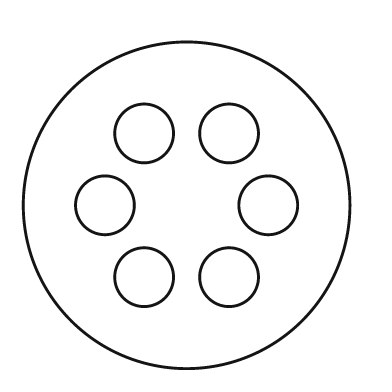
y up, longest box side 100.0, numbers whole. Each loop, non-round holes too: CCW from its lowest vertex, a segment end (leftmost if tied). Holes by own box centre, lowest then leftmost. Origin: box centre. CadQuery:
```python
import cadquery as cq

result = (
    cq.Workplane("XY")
    .moveTo(0.0, 0.0)
    .circle(50.0)
    .moveTo(-13.0, -22.0)
    .circle(9.0)
    .moveTo(13.0, -22.0)
    .circle(9.0)
    .moveTo(-25.0, 0.0)
    .circle(9.0)
    .moveTo(25.0, 0.0)
    .circle(9.0)
    .moveTo(-13.0, 22.0)
    .circle(9.0)
    .moveTo(13.0, 22.0)
    .circle(9.0)
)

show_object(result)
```